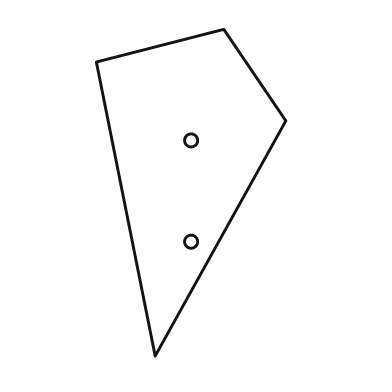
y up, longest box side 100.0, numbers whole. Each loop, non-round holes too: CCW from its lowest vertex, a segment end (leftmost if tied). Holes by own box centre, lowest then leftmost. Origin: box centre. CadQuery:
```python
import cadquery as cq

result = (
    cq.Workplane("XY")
    .moveTo(-11.0, -50.0)
    .lineTo(29.0, 22.0)
    .lineTo(10.0, 50.0)
    .lineTo(-29.0, 40.0)
    .close()
    .moveTo(0.0, -15.0)
    .circle(2.0)
    .moveTo(0.0, 16.0)
    .circle(2.0)
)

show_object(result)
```